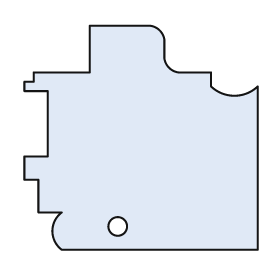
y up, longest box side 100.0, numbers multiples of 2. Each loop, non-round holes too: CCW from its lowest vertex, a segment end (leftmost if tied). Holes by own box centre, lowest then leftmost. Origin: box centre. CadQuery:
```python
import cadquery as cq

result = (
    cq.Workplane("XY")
    .moveTo(-34.0, -48.0)
    .lineTo(50.0, -48.0)
    .lineTo(50.0, 22.0)
    .threePointArc((40.0, 18.0), (30.0, 22.0))
    .lineTo(30.0, 28.0)
    .lineTo(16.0, 28.0)
    .threePointArc((12.0, 30.0), (10.0, 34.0))
    .lineTo(10.0, 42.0)
    .threePointArc((8.0, 46.0), (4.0, 48.0))
    .lineTo(-22.0, 48.0)
    .lineTo(-22.0, 28.0)
    .lineTo(-46.0, 28.0)
    .lineTo(-46.0, 24.0)
    .lineTo(-50.0, 24.0)
    .lineTo(-50.0, 20.0)
    .lineTo(-40.0, 20.0)
    .lineTo(-40.0, -8.0)
    .lineTo(-50.0, -8.0)
    .lineTo(-50.0, -18.0)
    .lineTo(-44.0, -18.0)
    .lineTo(-44.0, -32.0)
    .lineTo(-34.0, -32.0)
    .threePointArc((-38.0, -40.0), (-34.0, -48.0))
    .close()
    .moveTo(-10.0, -38.0)
    .circle(4.0)
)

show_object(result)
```